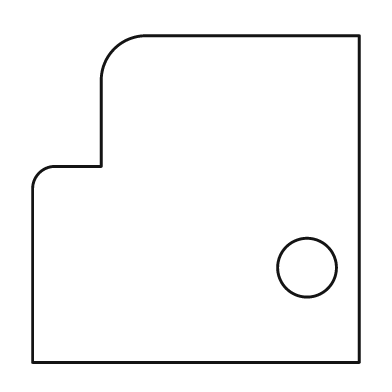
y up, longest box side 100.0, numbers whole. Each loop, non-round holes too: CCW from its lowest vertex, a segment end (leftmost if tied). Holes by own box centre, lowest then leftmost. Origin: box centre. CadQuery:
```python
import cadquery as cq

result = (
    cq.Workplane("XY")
    .moveTo(-50.0, -50.0)
    .lineTo(50.0, -50.0)
    .lineTo(50.0, 50.0)
    .lineTo(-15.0, 50.0)
    .threePointArc((-25.0, 46.0), (-29.0, 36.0))
    .lineTo(-29.0, 10.0)
    .lineTo(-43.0, 10.0)
    .threePointArc((-48.0, 8.0), (-50.0, 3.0))
    .close()
    .moveTo(34.0, -21.0)
    .circle(9.0)
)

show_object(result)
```